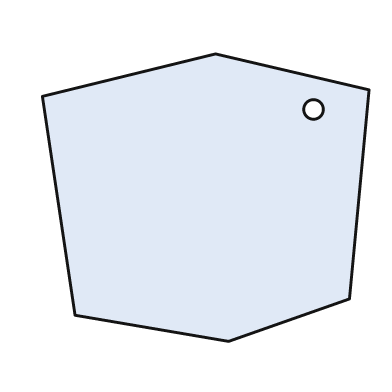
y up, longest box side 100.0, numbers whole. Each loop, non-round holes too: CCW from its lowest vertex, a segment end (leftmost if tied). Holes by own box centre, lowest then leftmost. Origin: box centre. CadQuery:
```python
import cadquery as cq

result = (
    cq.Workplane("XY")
    .moveTo(7.0, -44.0)
    .lineTo(44.0, -31.0)
    .lineTo(50.0, 33.0)
    .lineTo(3.0, 44.0)
    .lineTo(-50.0, 31.0)
    .lineTo(-40.0, -36.0)
    .close()
    .moveTo(33.0, 27.0)
    .circle(3.0)
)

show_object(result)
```